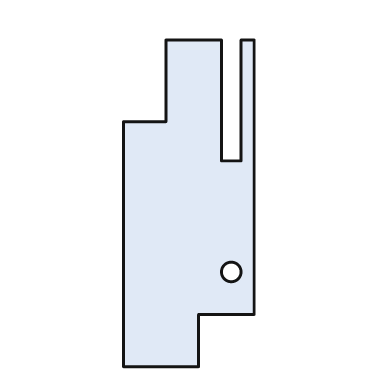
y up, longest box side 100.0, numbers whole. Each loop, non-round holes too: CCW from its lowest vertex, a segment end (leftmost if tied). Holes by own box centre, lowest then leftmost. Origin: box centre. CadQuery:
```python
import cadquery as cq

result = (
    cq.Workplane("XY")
    .moveTo(-20.0, -50.0)
    .lineTo(3.0, -50.0)
    .lineTo(3.0, -34.0)
    .lineTo(20.0, -34.0)
    .lineTo(20.0, 50.0)
    .lineTo(16.0, 50.0)
    .lineTo(16.0, 13.0)
    .lineTo(10.0, 13.0)
    .lineTo(10.0, 50.0)
    .lineTo(-7.0, 50.0)
    .lineTo(-7.0, 25.0)
    .lineTo(-20.0, 25.0)
    .close()
    .moveTo(13.0, -21.0)
    .circle(3.0)
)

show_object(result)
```